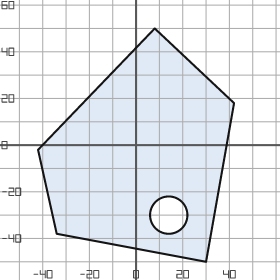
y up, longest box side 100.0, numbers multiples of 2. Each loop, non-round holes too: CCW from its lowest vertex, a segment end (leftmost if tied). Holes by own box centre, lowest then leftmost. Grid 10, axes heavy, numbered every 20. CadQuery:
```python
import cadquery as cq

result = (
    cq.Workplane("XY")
    .moveTo(30.0, -50.0)
    .lineTo(42.0, 18.0)
    .lineTo(8.0, 50.0)
    .lineTo(-42.0, -2.0)
    .lineTo(-34.0, -38.0)
    .close()
    .moveTo(14.0, -30.0)
    .circle(8.0)
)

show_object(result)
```